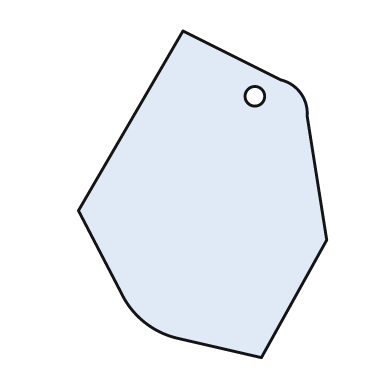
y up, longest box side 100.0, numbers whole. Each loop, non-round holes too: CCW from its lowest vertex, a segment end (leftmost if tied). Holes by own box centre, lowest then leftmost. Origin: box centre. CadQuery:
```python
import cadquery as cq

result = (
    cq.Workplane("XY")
    .moveTo(18.0, -50.0)
    .lineTo(38.0, -14.0)
    .lineTo(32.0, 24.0)
    .threePointArc((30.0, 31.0), (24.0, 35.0))
    .lineTo(-6.0, 50.0)
    .lineTo(-38.0, -5.0)
    .lineTo(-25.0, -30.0)
    .threePointArc((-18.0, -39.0), (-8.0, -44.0))
    .close()
    .moveTo(16.0, 30.0)
    .circle(3.0)
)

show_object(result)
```